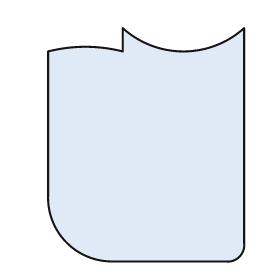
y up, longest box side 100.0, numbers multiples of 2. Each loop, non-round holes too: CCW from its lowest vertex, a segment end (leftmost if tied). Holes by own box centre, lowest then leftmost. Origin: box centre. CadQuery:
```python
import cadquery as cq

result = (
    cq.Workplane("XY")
    .moveTo(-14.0, -50.0)
    .lineTo(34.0, -50.0)
    .threePointArc((40.0, -48.0), (42.0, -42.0))
    .lineTo(42.0, 50.0)
    .threePointArc((16.0, 40.0), (-10.0, 50.0))
    .lineTo(-10.0, 40.0)
    .threePointArc((-26.0, 42.0), (-42.0, 40.0))
    .lineTo(-42.0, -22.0)
    .threePointArc((-34.0, -42.0), (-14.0, -50.0))
    .close()
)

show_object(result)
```